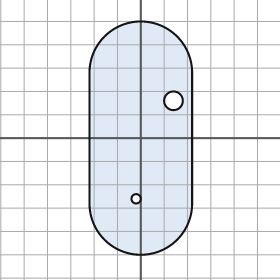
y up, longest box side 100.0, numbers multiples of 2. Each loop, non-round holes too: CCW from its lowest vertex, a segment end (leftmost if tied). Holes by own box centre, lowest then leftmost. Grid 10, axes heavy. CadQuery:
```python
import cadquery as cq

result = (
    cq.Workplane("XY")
    .moveTo(-22.0, -28.0)
    .threePointArc((0.0, -50.0), (22.0, -28.0))
    .lineTo(22.0, 28.0)
    .threePointArc((0.0, 50.0), (-22.0, 28.0))
    .close()
    .moveTo(-2.0, -26.0)
    .circle(2.0)
    .moveTo(14.0, 16.0)
    .circle(4.0)
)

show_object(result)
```